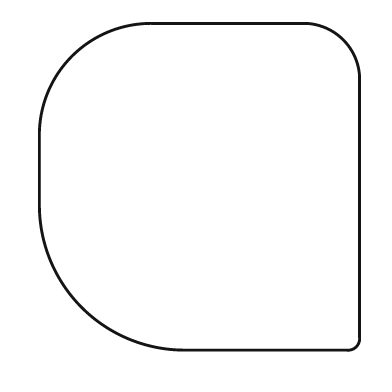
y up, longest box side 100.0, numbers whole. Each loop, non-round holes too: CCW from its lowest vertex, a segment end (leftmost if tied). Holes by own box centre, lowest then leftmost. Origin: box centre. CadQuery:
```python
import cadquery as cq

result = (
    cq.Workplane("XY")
    .moveTo(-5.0, -50.0)
    .lineTo(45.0, -50.0)
    .threePointArc((48.0, -49.0), (49.0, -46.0))
    .lineTo(49.0, 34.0)
    .threePointArc((44.0, 45.0), (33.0, 50.0))
    .lineTo(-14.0, 50.0)
    .threePointArc((-39.0, 40.0), (-49.0, 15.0))
    .lineTo(-49.0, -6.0)
    .threePointArc((-36.0, -37.0), (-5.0, -50.0))
    .close()
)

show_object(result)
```